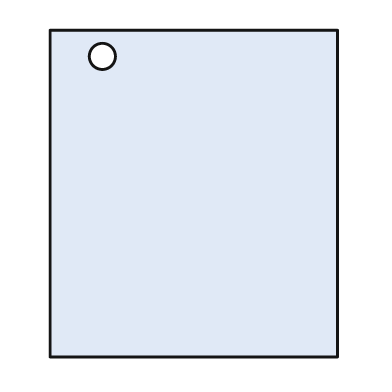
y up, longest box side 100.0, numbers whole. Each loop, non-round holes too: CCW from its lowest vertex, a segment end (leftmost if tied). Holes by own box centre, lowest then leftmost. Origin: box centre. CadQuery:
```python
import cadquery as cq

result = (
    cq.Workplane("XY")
    .moveTo(-44.0, -50.0)
    .lineTo(44.0, -50.0)
    .lineTo(44.0, 50.0)
    .lineTo(-44.0, 50.0)
    .close()
    .moveTo(-28.0, 42.0)
    .circle(4.0)
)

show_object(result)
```